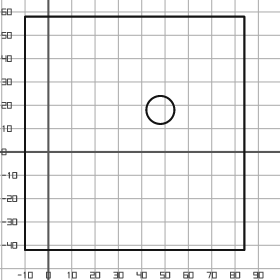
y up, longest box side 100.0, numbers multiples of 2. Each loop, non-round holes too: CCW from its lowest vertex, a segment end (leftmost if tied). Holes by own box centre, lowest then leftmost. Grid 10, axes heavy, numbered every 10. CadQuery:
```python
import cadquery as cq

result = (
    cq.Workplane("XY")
    .moveTo(-10.0, -42.0)
    .lineTo(84.0, -42.0)
    .lineTo(84.0, 58.0)
    .lineTo(-10.0, 58.0)
    .close()
    .moveTo(48.0, 18.0)
    .circle(6.0)
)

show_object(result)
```